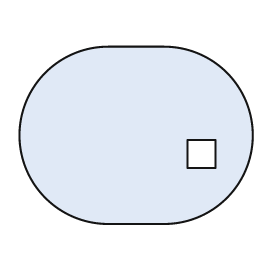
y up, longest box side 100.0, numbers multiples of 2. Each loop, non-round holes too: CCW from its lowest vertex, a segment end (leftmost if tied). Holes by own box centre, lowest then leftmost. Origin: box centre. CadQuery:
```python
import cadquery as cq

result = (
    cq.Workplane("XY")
    .moveTo(-12.0, -38.0)
    .lineTo(12.0, -38.0)
    .threePointArc((50.0, 0.0), (12.0, 38.0))
    .lineTo(-12.0, 38.0)
    .threePointArc((-50.0, 0.0), (-12.0, -38.0))
    .close()
    .moveTo(22.0, -14.0)
    .lineTo(34.0, -14.0)
    .lineTo(34.0, -2.0)
    .lineTo(22.0, -2.0)
    .close()
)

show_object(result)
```